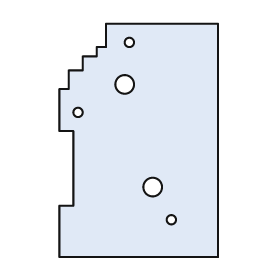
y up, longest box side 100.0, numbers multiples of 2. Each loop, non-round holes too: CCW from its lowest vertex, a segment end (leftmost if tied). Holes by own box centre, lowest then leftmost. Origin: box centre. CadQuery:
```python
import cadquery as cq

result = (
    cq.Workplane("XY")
    .moveTo(-34.0, -50.0)
    .lineTo(34.0, -50.0)
    .lineTo(34.0, 50.0)
    .lineTo(-14.0, 50.0)
    .lineTo(-14.0, 40.0)
    .lineTo(-18.0, 40.0)
    .lineTo(-18.0, 36.0)
    .lineTo(-24.0, 36.0)
    .lineTo(-24.0, 30.0)
    .lineTo(-30.0, 30.0)
    .lineTo(-30.0, 22.0)
    .lineTo(-34.0, 22.0)
    .lineTo(-34.0, 4.0)
    .lineTo(-28.0, 4.0)
    .lineTo(-28.0, -28.0)
    .lineTo(-34.0, -28.0)
    .close()
    .moveTo(14.0, -34.0)
    .circle(2.0)
    .moveTo(6.0, -20.0)
    .circle(4.0)
    .moveTo(-26.0, 12.0)
    .circle(2.0)
    .moveTo(-6.0, 24.0)
    .circle(4.0)
    .moveTo(-4.0, 42.0)
    .circle(2.0)
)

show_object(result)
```